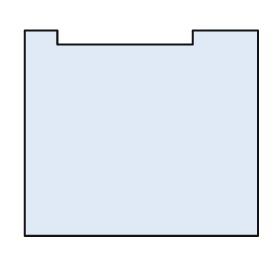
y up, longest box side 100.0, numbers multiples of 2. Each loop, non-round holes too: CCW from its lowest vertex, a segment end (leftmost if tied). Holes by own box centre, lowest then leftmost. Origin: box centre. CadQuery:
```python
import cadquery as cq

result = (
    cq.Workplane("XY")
    .moveTo(-50.0, -44.0)
    .lineTo(50.0, -44.0)
    .lineTo(50.0, 44.0)
    .lineTo(22.0, 44.0)
    .lineTo(22.0, 38.0)
    .lineTo(-36.0, 38.0)
    .lineTo(-36.0, 44.0)
    .lineTo(-50.0, 44.0)
    .close()
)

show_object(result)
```